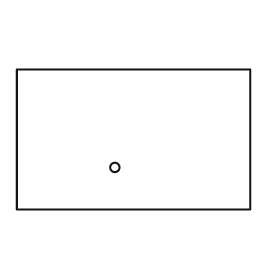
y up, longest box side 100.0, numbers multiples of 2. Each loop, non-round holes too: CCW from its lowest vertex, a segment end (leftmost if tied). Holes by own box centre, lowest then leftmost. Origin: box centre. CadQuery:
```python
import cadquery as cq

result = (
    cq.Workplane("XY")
    .moveTo(-50.0, -30.0)
    .lineTo(50.0, -30.0)
    .lineTo(50.0, 30.0)
    .lineTo(-50.0, 30.0)
    .close()
    .moveTo(-8.0, -12.0)
    .circle(2.0)
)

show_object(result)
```